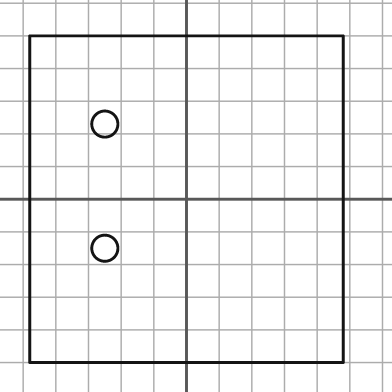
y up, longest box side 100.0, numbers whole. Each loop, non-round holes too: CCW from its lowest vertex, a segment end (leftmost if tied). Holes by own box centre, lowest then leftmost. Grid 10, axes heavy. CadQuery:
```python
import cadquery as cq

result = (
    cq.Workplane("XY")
    .moveTo(-48.0, -50.0)
    .lineTo(48.0, -50.0)
    .lineTo(48.0, 50.0)
    .lineTo(-48.0, 50.0)
    .close()
    .moveTo(-25.0, -15.0)
    .circle(4.0)
    .moveTo(-25.0, 23.0)
    .circle(4.0)
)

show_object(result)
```